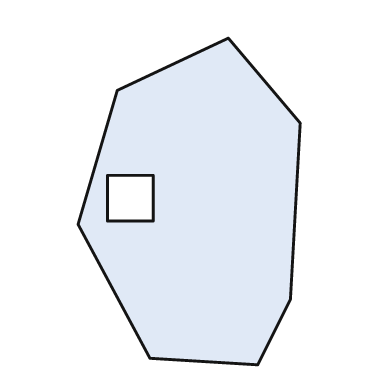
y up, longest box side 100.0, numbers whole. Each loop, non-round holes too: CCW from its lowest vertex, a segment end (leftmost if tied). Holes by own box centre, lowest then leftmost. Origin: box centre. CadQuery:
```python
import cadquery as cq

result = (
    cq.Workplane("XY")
    .moveTo(21.0, -50.0)
    .lineTo(31.0, -30.0)
    .lineTo(34.0, 24.0)
    .lineTo(12.0, 50.0)
    .lineTo(-22.0, 34.0)
    .lineTo(-34.0, -7.0)
    .lineTo(-12.0, -48.0)
    .close()
    .moveTo(-25.0, -6.0)
    .lineTo(-11.0, -6.0)
    .lineTo(-11.0, 8.0)
    .lineTo(-25.0, 8.0)
    .close()
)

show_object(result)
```